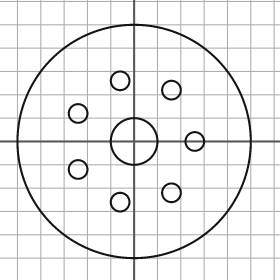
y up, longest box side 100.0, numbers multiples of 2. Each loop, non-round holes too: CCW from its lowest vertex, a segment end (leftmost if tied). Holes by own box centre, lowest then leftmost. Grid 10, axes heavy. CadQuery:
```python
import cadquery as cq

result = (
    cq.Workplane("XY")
    .moveTo(0.0, 0.0)
    .circle(50.0)
    .moveTo(-6.0, -26.0)
    .circle(4.0)
    .moveTo(16.0, -22.0)
    .circle(4.0)
    .moveTo(-24.0, -12.0)
    .circle(4.0)
    .moveTo(0.0, 0.0)
    .circle(10.0)
    .moveTo(26.0, 0.0)
    .circle(4.0)
    .moveTo(-24.0, 12.0)
    .circle(4.0)
    .moveTo(16.0, 22.0)
    .circle(4.0)
    .moveTo(-6.0, 26.0)
    .circle(4.0)
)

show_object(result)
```